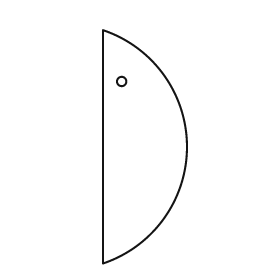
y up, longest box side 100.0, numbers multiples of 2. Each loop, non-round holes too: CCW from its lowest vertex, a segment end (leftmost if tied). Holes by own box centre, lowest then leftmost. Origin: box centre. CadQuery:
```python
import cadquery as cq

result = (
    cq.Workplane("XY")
    .moveTo(-18.0, -50.0)
    .threePointArc((18.0, 0.0), (-18.0, 50.0))
    .close()
    .moveTo(-10.0, 28.0)
    .circle(2.0)
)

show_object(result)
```